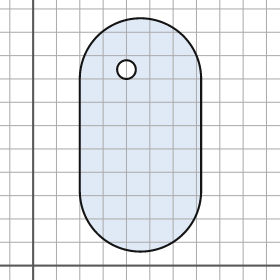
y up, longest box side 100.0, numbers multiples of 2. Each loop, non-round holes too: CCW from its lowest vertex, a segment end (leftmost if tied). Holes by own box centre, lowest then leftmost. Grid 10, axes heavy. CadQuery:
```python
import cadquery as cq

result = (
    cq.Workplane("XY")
    .moveTo(20.0, 32.0)
    .threePointArc((46.0, 6.0), (72.0, 32.0))
    .lineTo(72.0, 80.0)
    .threePointArc((46.0, 106.0), (20.0, 80.0))
    .close()
    .moveTo(40.0, 84.0)
    .circle(4.0)
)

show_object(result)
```